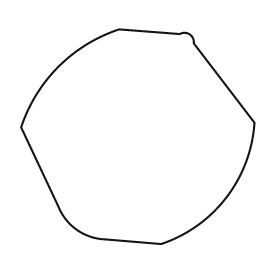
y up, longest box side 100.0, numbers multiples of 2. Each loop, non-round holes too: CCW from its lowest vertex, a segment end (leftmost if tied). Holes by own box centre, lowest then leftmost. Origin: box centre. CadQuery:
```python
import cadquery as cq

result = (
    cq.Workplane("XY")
    .moveTo(10.0, -46.0)
    .threePointArc((38.0, -26.0), (50.0, 6.0))
    .lineTo(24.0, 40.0)
    .threePointArc((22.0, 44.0), (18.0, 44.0))
    .lineTo(-8.0, 46.0)
    .threePointArc((-34.0, 30.0), (-50.0, 4.0))
    .lineTo(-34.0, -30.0)
    .threePointArc((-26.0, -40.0), (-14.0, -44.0))
    .close()
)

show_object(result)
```